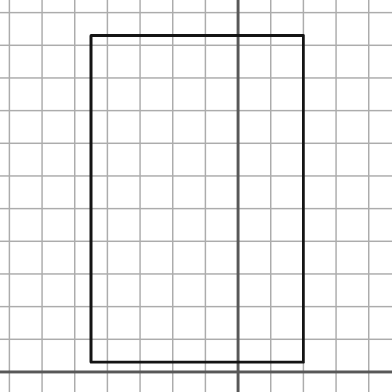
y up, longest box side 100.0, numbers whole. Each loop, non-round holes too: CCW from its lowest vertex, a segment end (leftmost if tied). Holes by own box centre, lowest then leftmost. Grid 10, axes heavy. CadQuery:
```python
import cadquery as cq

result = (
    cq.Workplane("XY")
    .moveTo(-45.0, 3.0)
    .lineTo(20.0, 3.0)
    .lineTo(20.0, 103.0)
    .lineTo(-45.0, 103.0)
    .close()
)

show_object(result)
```